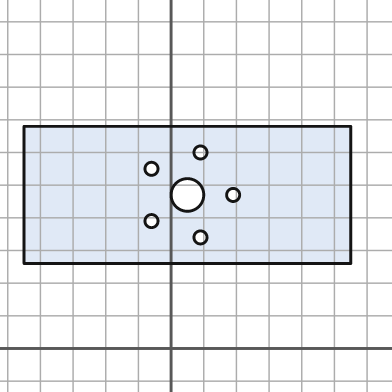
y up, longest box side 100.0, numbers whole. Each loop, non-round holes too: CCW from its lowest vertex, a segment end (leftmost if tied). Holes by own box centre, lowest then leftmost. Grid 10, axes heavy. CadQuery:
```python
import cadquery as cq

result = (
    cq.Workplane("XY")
    .moveTo(-45.0, 26.0)
    .lineTo(55.0, 26.0)
    .lineTo(55.0, 68.0)
    .lineTo(-45.0, 68.0)
    .close()
    .moveTo(9.0, 34.0)
    .circle(2.0)
    .moveTo(-6.0, 39.0)
    .circle(2.0)
    .moveTo(5.0, 47.0)
    .circle(5.0)
    .moveTo(19.0, 47.0)
    .circle(2.0)
    .moveTo(-6.0, 55.0)
    .circle(2.0)
    .moveTo(9.0, 60.0)
    .circle(2.0)
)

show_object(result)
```